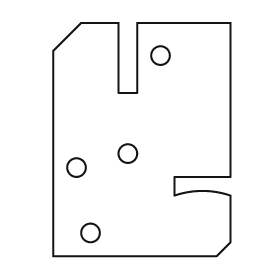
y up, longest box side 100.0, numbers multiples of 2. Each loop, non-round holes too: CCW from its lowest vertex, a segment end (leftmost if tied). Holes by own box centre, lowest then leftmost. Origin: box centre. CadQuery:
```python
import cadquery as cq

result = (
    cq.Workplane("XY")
    .moveTo(-38.0, -50.0)
    .lineTo(32.0, -50.0)
    .lineTo(38.0, -44.0)
    .lineTo(38.0, -24.0)
    .threePointArc((26.0, -22.0), (14.0, -24.0))
    .lineTo(14.0, -16.0)
    .lineTo(38.0, -16.0)
    .lineTo(38.0, 50.0)
    .lineTo(-2.0, 50.0)
    .lineTo(-2.0, 20.0)
    .lineTo(-10.0, 20.0)
    .lineTo(-10.0, 50.0)
    .lineTo(-26.0, 50.0)
    .lineTo(-38.0, 38.0)
    .close()
    .moveTo(-22.0, -40.0)
    .circle(4.0)
    .moveTo(-28.0, -12.0)
    .circle(4.0)
    .moveTo(-6.0, -6.0)
    .circle(4.0)
    .moveTo(8.0, 36.0)
    .circle(4.0)
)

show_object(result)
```